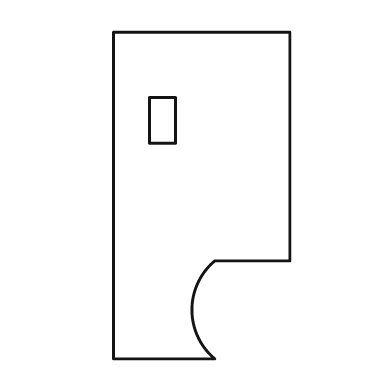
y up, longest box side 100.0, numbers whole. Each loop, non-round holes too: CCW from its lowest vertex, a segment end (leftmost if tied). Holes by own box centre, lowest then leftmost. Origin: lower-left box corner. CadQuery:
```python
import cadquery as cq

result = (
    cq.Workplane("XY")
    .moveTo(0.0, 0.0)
    .lineTo(31.0, 0.0)
    .threePointArc((24.0, 15.0), (31.0, 30.0))
    .lineTo(54.0, 30.0)
    .lineTo(54.0, 100.0)
    .lineTo(0.0, 100.0)
    .close()
    .moveTo(11.0, 66.0)
    .lineTo(19.0, 66.0)
    .lineTo(19.0, 80.0)
    .lineTo(11.0, 80.0)
    .close()
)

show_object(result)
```